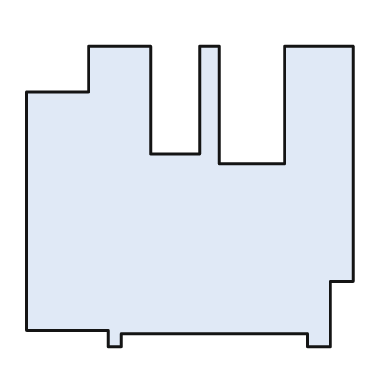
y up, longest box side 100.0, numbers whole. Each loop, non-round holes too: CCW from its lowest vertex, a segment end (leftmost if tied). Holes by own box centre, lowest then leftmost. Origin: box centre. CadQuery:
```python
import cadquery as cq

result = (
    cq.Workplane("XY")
    .moveTo(-25.0, -46.0)
    .lineTo(-21.0, -46.0)
    .lineTo(-21.0, -42.0)
    .lineTo(36.0, -42.0)
    .lineTo(36.0, -46.0)
    .lineTo(43.0, -46.0)
    .lineTo(43.0, -26.0)
    .lineTo(50.0, -26.0)
    .lineTo(50.0, 46.0)
    .lineTo(29.0, 46.0)
    .lineTo(29.0, 10.0)
    .lineTo(9.0, 10.0)
    .lineTo(9.0, 46.0)
    .lineTo(3.0, 46.0)
    .lineTo(3.0, 13.0)
    .lineTo(-12.0, 13.0)
    .lineTo(-12.0, 46.0)
    .lineTo(-31.0, 46.0)
    .lineTo(-31.0, 32.0)
    .lineTo(-50.0, 32.0)
    .lineTo(-50.0, -41.0)
    .lineTo(-25.0, -41.0)
    .close()
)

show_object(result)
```